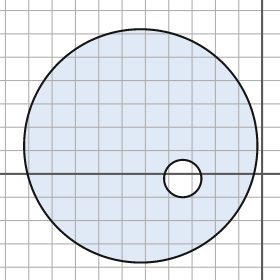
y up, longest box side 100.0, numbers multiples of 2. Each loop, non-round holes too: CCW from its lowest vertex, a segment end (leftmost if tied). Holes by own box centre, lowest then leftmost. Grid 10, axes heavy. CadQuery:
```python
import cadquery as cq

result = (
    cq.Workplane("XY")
    .moveTo(-52.0, 12.0)
    .circle(50.0)
    .moveTo(-34.0, -2.0)
    .circle(8.0)
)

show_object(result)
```